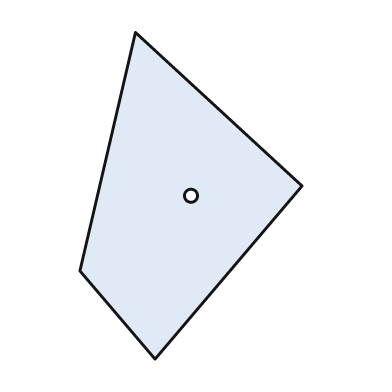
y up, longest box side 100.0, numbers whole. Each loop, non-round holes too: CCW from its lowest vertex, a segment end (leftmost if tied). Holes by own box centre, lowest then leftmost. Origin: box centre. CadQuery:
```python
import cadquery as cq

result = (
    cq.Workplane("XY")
    .moveTo(-11.0, -50.0)
    .lineTo(34.0, 3.0)
    .lineTo(-17.0, 50.0)
    .lineTo(-34.0, -23.0)
    .close()
    .moveTo(0.0, 0.0)
    .circle(2.0)
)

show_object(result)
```